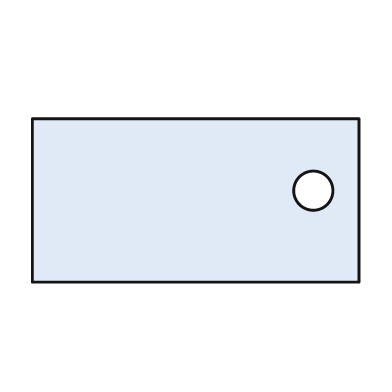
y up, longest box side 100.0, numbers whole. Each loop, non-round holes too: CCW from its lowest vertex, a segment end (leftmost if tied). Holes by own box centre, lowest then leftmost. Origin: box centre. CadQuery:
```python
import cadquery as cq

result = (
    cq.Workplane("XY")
    .moveTo(-50.0, -25.0)
    .lineTo(50.0, -25.0)
    .lineTo(50.0, 25.0)
    .lineTo(-50.0, 25.0)
    .close()
    .moveTo(36.0, 3.0)
    .circle(6.0)
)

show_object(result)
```